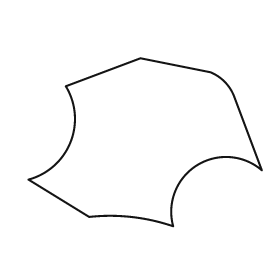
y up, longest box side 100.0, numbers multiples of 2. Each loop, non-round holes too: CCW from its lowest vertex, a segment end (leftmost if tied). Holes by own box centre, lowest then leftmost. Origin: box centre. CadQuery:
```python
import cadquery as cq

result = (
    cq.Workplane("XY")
    .moveTo(12.0, -36.0)
    .threePointArc((22.0, -10.0), (50.0, -12.0))
    .lineTo(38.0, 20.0)
    .threePointArc((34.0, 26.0), (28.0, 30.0))
    .lineTo(-2.0, 36.0)
    .lineTo(-34.0, 24.0)
    .threePointArc((-32.0, 0.0), (-50.0, -16.0))
    .lineTo(-24.0, -32.0)
    .threePointArc((-6.0, -32.0), (12.0, -36.0))
    .close()
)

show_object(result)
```